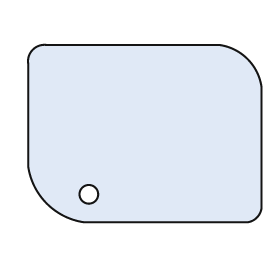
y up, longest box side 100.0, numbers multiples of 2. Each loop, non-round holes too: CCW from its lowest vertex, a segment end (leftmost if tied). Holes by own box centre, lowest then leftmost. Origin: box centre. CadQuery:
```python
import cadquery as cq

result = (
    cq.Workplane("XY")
    .moveTo(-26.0, -38.0)
    .lineTo(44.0, -38.0)
    .threePointArc((48.0, -36.0), (50.0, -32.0))
    .lineTo(50.0, 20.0)
    .threePointArc((44.0, 32.0), (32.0, 38.0))
    .lineTo(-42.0, 38.0)
    .threePointArc((-48.0, 36.0), (-50.0, 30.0))
    .lineTo(-50.0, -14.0)
    .threePointArc((-42.0, -30.0), (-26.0, -38.0))
    .close()
    .moveTo(-24.0, -26.0)
    .circle(4.0)
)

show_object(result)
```